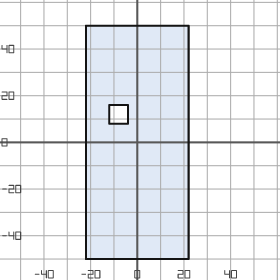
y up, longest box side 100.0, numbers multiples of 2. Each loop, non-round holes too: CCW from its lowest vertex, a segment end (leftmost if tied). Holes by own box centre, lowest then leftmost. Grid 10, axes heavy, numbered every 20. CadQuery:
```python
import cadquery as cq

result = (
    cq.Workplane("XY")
    .moveTo(-22.0, -50.0)
    .lineTo(22.0, -50.0)
    .lineTo(22.0, 50.0)
    .lineTo(-22.0, 50.0)
    .close()
    .moveTo(-12.0, 8.0)
    .lineTo(-4.0, 8.0)
    .lineTo(-4.0, 16.0)
    .lineTo(-12.0, 16.0)
    .close()
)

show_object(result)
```